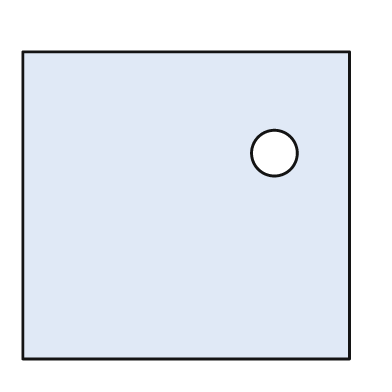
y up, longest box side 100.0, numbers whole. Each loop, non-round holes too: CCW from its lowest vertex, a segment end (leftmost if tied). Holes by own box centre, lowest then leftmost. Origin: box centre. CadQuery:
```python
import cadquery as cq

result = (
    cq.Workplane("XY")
    .moveTo(-50.0, -47.0)
    .lineTo(50.0, -47.0)
    .lineTo(50.0, 47.0)
    .lineTo(-50.0, 47.0)
    .close()
    .moveTo(27.0, 16.0)
    .circle(7.0)
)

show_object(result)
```